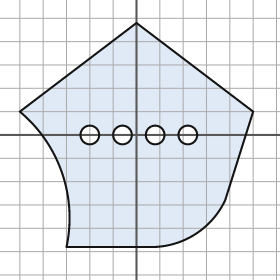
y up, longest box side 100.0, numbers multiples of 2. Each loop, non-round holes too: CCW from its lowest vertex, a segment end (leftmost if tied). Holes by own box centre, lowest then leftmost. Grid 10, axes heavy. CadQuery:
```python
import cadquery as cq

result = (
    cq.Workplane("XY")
    .moveTo(-30.0, -48.0)
    .lineTo(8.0, -48.0)
    .threePointArc((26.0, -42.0), (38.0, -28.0))
    .lineTo(50.0, 10.0)
    .lineTo(0.0, 48.0)
    .lineTo(-50.0, 10.0)
    .threePointArc((-32.0, -16.0), (-30.0, -48.0))
    .close()
    .moveTo(-20.0, 0.0)
    .circle(4.0)
    .moveTo(-6.0, 0.0)
    .circle(4.0)
    .moveTo(8.0, 0.0)
    .circle(4.0)
    .moveTo(22.0, 0.0)
    .circle(4.0)
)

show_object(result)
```